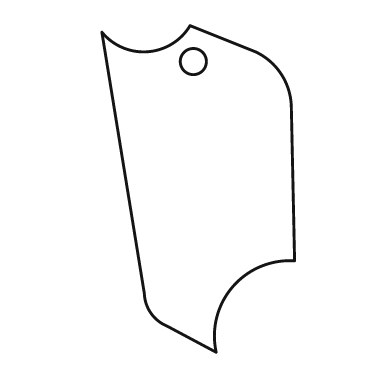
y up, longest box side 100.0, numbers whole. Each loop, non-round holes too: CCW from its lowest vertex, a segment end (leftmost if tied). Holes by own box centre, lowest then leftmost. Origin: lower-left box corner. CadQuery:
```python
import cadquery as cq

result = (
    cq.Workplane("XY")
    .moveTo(35.0, 0.0)
    .threePointArc((40.0, 20.0), (59.0, 28.0))
    .lineTo(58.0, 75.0)
    .threePointArc((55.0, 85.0), (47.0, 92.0))
    .lineTo(27.0, 100.0)
    .threePointArc((14.0, 92.0), (0.0, 98.0))
    .lineTo(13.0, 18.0)
    .threePointArc((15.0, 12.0), (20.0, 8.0))
    .close()
    .moveTo(28.0, 89.0)
    .circle(4.0)
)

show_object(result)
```